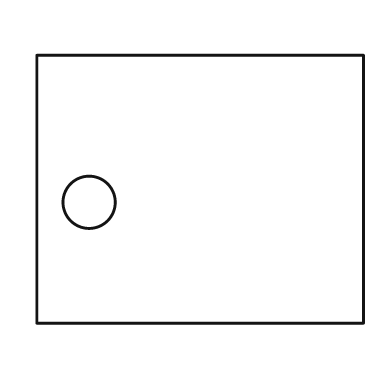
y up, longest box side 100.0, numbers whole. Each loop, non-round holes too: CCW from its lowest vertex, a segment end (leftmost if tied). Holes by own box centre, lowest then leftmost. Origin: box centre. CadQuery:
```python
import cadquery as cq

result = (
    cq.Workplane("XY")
    .moveTo(-50.0, -41.0)
    .lineTo(50.0, -41.0)
    .lineTo(50.0, 41.0)
    .lineTo(-50.0, 41.0)
    .close()
    .moveTo(-34.0, -4.0)
    .circle(8.0)
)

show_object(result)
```